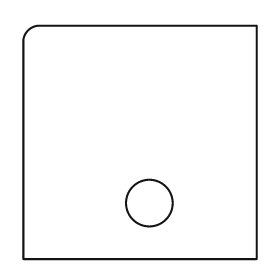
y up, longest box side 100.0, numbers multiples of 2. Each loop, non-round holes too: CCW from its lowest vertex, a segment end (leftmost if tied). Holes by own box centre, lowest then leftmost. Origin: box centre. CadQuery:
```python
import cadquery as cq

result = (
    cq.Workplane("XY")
    .moveTo(-50.0, -50.0)
    .lineTo(50.0, -50.0)
    .lineTo(50.0, 50.0)
    .lineTo(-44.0, 50.0)
    .threePointArc((-48.0, 48.0), (-50.0, 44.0))
    .close()
    .moveTo(4.0, -26.0)
    .circle(10.0)
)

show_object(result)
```